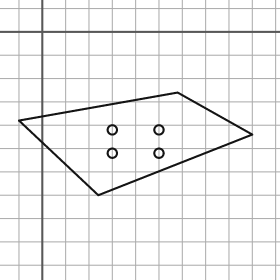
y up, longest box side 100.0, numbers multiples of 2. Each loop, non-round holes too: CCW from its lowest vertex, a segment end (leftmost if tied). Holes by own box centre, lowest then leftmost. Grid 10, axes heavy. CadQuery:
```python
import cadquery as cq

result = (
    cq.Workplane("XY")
    .moveTo(24.0, -70.0)
    .lineTo(90.0, -44.0)
    .lineTo(58.0, -26.0)
    .lineTo(-10.0, -38.0)
    .close()
    .moveTo(30.0, -52.0)
    .circle(2.0)
    .moveTo(50.0, -52.0)
    .circle(2.0)
    .moveTo(30.0, -42.0)
    .circle(2.0)
    .moveTo(50.0, -42.0)
    .circle(2.0)
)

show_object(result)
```